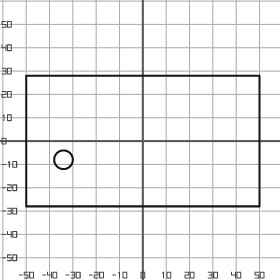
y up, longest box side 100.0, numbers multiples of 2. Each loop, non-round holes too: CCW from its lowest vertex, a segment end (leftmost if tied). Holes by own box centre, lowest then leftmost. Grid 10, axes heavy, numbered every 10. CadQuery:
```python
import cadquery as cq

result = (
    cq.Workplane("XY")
    .moveTo(-50.0, -28.0)
    .lineTo(50.0, -28.0)
    .lineTo(50.0, 28.0)
    .lineTo(-50.0, 28.0)
    .close()
    .moveTo(-34.0, -8.0)
    .circle(4.0)
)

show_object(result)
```